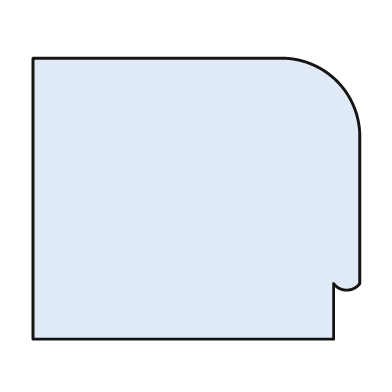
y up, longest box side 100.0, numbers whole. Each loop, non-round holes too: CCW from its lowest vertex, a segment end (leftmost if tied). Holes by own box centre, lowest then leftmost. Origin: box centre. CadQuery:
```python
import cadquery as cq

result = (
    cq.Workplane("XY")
    .moveTo(-50.0, -43.0)
    .lineTo(42.0, -43.0)
    .lineTo(42.0, -26.0)
    .threePointArc((46.0, -28.0), (50.0, -26.0))
    .lineTo(50.0, 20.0)
    .threePointArc((43.0, 36.0), (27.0, 43.0))
    .lineTo(-50.0, 43.0)
    .close()
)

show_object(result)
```